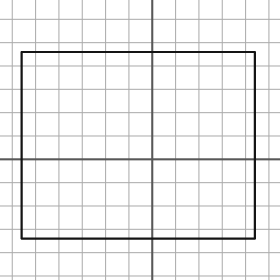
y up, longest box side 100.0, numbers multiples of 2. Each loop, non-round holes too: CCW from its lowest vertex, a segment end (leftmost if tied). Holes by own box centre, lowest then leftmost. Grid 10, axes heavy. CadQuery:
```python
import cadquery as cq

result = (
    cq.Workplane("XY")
    .moveTo(-56.0, -34.0)
    .lineTo(44.0, -34.0)
    .lineTo(44.0, 46.0)
    .lineTo(-56.0, 46.0)
    .close()
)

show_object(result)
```